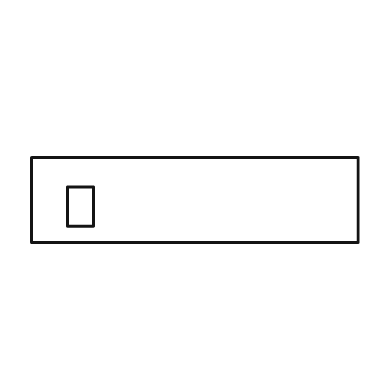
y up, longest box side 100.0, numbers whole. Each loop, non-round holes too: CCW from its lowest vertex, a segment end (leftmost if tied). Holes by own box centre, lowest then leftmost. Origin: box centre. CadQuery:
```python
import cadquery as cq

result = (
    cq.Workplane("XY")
    .moveTo(-50.0, -13.0)
    .lineTo(50.0, -13.0)
    .lineTo(50.0, 13.0)
    .lineTo(-50.0, 13.0)
    .close()
    .moveTo(-39.0, -8.0)
    .lineTo(-31.0, -8.0)
    .lineTo(-31.0, 4.0)
    .lineTo(-39.0, 4.0)
    .close()
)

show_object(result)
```